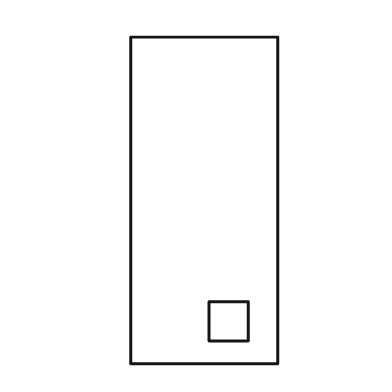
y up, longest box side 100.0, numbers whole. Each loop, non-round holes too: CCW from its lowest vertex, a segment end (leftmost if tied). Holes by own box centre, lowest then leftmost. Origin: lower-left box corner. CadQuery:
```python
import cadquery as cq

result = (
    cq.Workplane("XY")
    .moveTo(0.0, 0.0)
    .lineTo(45.0, 0.0)
    .lineTo(45.0, 100.0)
    .lineTo(0.0, 100.0)
    .close()
    .moveTo(24.0, 7.0)
    .lineTo(36.0, 7.0)
    .lineTo(36.0, 19.0)
    .lineTo(24.0, 19.0)
    .close()
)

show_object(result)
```